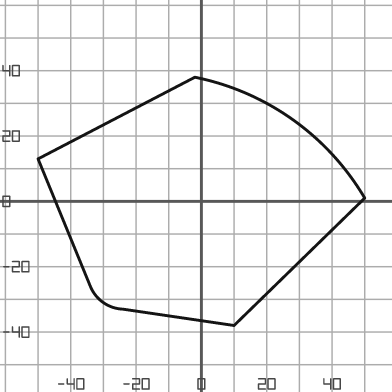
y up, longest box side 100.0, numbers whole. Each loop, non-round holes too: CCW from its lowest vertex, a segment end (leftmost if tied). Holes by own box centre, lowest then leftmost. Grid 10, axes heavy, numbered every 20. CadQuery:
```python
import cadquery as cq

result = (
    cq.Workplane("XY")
    .moveTo(10.0, -38.0)
    .lineTo(50.0, 1.0)
    .threePointArc((28.0, 25.0), (-2.0, 38.0))
    .lineTo(-50.0, 13.0)
    .lineTo(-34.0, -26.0)
    .threePointArc((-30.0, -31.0), (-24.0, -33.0))
    .close()
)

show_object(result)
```